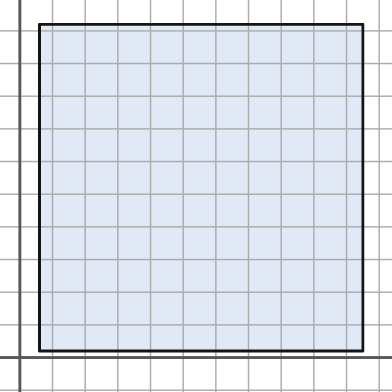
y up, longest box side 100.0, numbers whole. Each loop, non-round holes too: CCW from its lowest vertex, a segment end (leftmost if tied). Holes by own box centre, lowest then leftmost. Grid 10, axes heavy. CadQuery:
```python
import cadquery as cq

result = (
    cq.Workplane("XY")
    .moveTo(6.0, 2.0)
    .lineTo(105.0, 2.0)
    .lineTo(105.0, 102.0)
    .lineTo(6.0, 102.0)
    .close()
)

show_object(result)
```